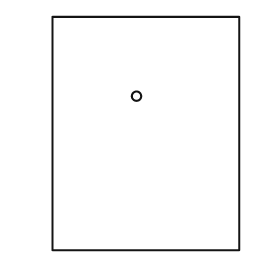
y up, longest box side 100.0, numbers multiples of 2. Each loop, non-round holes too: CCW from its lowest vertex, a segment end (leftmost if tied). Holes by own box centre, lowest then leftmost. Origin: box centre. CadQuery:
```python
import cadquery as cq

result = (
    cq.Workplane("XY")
    .moveTo(-40.0, -50.0)
    .lineTo(40.0, -50.0)
    .lineTo(40.0, 50.0)
    .lineTo(-40.0, 50.0)
    .close()
    .moveTo(-4.0, 16.0)
    .circle(2.0)
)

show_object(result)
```